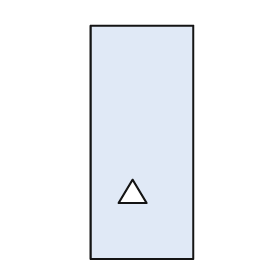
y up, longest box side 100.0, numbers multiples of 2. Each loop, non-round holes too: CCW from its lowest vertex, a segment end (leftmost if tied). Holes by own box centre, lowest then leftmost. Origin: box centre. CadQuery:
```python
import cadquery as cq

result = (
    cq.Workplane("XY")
    .moveTo(-22.0, -50.0)
    .lineTo(22.0, -50.0)
    .lineTo(22.0, 50.0)
    .lineTo(-22.0, 50.0)
    .close()
    .moveTo(-10.0, -26.0)
    .lineTo(2.0, -26.0)
    .lineTo(-4.0, -16.0)
    .close()
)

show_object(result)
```